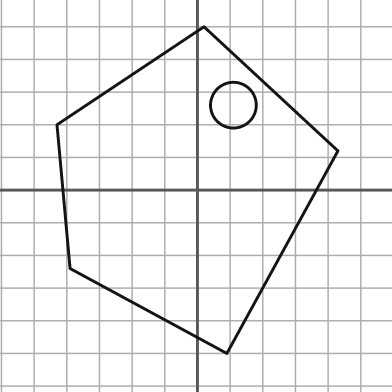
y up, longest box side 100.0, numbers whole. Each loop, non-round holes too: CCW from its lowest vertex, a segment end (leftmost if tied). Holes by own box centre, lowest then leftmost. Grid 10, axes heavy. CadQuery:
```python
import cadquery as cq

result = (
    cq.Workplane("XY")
    .moveTo(9.0, -50.0)
    .lineTo(43.0, 12.0)
    .lineTo(2.0, 50.0)
    .lineTo(-43.0, 20.0)
    .lineTo(-39.0, -24.0)
    .close()
    .moveTo(11.0, 26.0)
    .circle(7.0)
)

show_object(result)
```